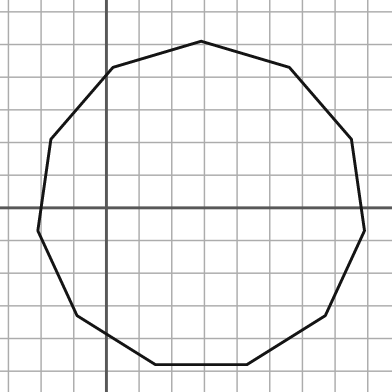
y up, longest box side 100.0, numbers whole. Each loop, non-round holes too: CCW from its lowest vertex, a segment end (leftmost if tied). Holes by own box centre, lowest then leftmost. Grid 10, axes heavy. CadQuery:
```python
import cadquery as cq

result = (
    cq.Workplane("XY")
    .moveTo(15.0, -48.0)
    .lineTo(43.0, -48.0)
    .lineTo(67.0, -33.0)
    .lineTo(79.0, -7.0)
    .lineTo(75.0, 21.0)
    .lineTo(56.0, 43.0)
    .lineTo(29.0, 51.0)
    .lineTo(2.0, 43.0)
    .lineTo(-17.0, 21.0)
    .lineTo(-21.0, -7.0)
    .lineTo(-9.0, -33.0)
    .close()
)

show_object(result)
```